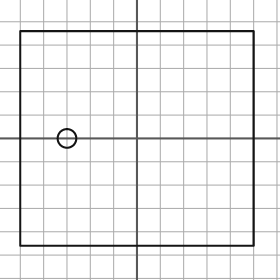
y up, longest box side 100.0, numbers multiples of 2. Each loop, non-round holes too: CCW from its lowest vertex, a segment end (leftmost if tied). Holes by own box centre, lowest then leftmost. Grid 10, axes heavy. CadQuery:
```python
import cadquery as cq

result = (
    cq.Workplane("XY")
    .moveTo(-50.0, -46.0)
    .lineTo(50.0, -46.0)
    .lineTo(50.0, 46.0)
    .lineTo(-50.0, 46.0)
    .close()
    .moveTo(-30.0, 0.0)
    .circle(4.0)
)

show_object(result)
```